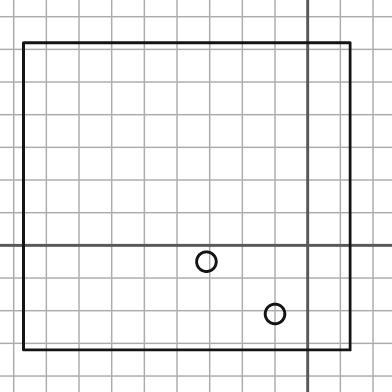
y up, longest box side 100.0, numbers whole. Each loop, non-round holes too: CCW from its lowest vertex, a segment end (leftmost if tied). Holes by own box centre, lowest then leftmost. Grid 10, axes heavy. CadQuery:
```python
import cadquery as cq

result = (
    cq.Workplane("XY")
    .moveTo(-87.0, -32.0)
    .lineTo(13.0, -32.0)
    .lineTo(13.0, 62.0)
    .lineTo(-87.0, 62.0)
    .close()
    .moveTo(-10.0, -21.0)
    .circle(3.0)
    .moveTo(-31.0, -5.0)
    .circle(3.0)
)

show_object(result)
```